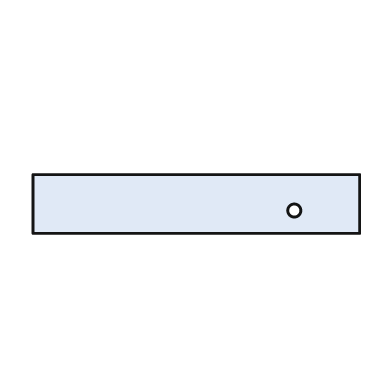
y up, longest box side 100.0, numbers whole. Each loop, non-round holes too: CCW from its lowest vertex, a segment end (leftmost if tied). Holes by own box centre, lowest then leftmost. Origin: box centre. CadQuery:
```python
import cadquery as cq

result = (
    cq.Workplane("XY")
    .moveTo(-50.0, -9.0)
    .lineTo(50.0, -9.0)
    .lineTo(50.0, 9.0)
    .lineTo(-50.0, 9.0)
    .close()
    .moveTo(30.0, -2.0)
    .circle(2.0)
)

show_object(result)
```